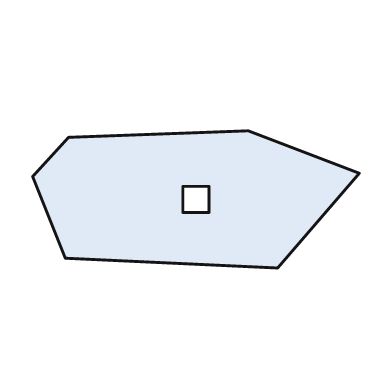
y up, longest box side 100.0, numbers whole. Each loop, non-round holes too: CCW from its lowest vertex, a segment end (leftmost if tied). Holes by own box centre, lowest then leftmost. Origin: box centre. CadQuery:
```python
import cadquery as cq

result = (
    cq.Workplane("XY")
    .moveTo(25.0, -21.0)
    .lineTo(50.0, 8.0)
    .lineTo(16.0, 21.0)
    .lineTo(-39.0, 19.0)
    .lineTo(-50.0, 7.0)
    .lineTo(-40.0, -18.0)
    .close()
    .moveTo(-4.0, -4.0)
    .lineTo(4.0, -4.0)
    .lineTo(4.0, 4.0)
    .lineTo(-4.0, 4.0)
    .close()
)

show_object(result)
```